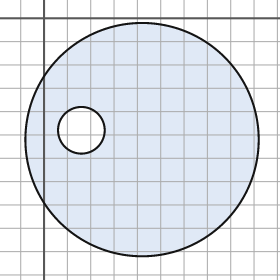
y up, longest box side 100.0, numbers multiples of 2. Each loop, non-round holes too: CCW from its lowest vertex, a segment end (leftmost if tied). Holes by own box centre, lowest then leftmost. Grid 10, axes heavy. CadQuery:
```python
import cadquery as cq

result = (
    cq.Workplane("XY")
    .moveTo(42.0, -52.0)
    .circle(50.0)
    .moveTo(16.0, -48.0)
    .circle(10.0)
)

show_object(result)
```